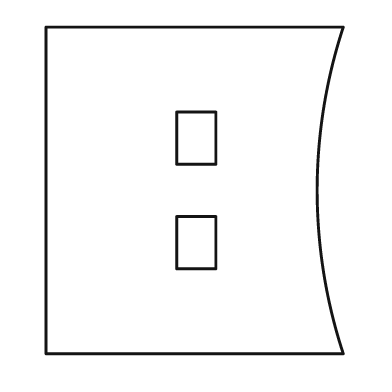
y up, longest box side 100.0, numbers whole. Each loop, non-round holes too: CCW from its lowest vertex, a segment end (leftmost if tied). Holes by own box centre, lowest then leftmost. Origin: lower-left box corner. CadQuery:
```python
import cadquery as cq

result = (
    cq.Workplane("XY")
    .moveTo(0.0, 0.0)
    .lineTo(91.0, 0.0)
    .threePointArc((83.0, 50.0), (91.0, 100.0))
    .lineTo(0.0, 100.0)
    .close()
    .moveTo(40.0, 26.0)
    .lineTo(52.0, 26.0)
    .lineTo(52.0, 42.0)
    .lineTo(40.0, 42.0)
    .close()
    .moveTo(40.0, 58.0)
    .lineTo(52.0, 58.0)
    .lineTo(52.0, 74.0)
    .lineTo(40.0, 74.0)
    .close()
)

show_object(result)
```